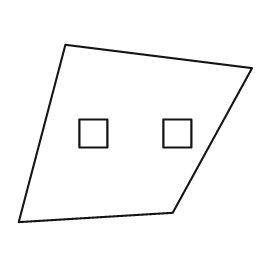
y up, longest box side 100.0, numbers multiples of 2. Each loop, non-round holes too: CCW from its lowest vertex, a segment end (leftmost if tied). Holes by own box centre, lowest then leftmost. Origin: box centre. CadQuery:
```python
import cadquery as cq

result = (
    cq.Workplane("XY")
    .moveTo(-50.0, -38.0)
    .lineTo(16.0, -34.0)
    .lineTo(50.0, 28.0)
    .lineTo(-30.0, 38.0)
    .close()
    .moveTo(-24.0, -6.0)
    .lineTo(-12.0, -6.0)
    .lineTo(-12.0, 6.0)
    .lineTo(-24.0, 6.0)
    .close()
    .moveTo(12.0, -6.0)
    .lineTo(24.0, -6.0)
    .lineTo(24.0, 6.0)
    .lineTo(12.0, 6.0)
    .close()
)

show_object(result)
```